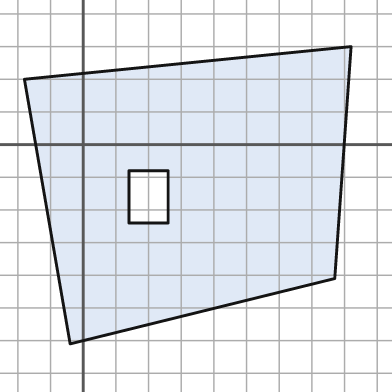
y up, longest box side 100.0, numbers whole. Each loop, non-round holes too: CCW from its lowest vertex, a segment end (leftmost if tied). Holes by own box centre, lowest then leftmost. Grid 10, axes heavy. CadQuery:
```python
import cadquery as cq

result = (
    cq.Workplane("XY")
    .moveTo(-4.0, -61.0)
    .lineTo(77.0, -41.0)
    .lineTo(82.0, 30.0)
    .lineTo(-18.0, 20.0)
    .close()
    .moveTo(14.0, -24.0)
    .lineTo(26.0, -24.0)
    .lineTo(26.0, -8.0)
    .lineTo(14.0, -8.0)
    .close()
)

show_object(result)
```